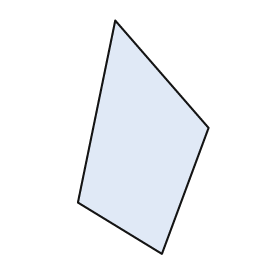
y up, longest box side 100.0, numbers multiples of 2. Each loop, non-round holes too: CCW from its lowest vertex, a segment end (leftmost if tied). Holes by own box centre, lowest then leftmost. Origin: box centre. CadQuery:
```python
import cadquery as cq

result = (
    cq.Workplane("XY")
    .moveTo(8.0, -50.0)
    .lineTo(28.0, 4.0)
    .lineTo(-12.0, 50.0)
    .lineTo(-28.0, -28.0)
    .close()
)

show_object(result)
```